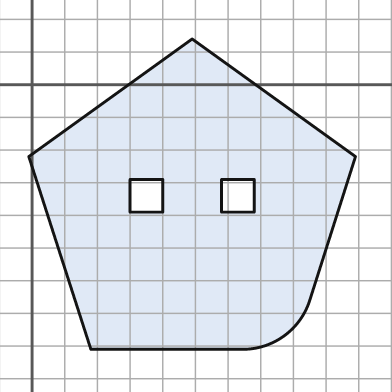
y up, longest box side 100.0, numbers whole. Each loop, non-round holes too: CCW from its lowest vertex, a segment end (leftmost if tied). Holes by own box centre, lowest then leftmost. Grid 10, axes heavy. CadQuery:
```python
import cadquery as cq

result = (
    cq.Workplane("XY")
    .moveTo(18.0, -81.0)
    .lineTo(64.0, -81.0)
    .threePointArc((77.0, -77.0), (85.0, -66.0))
    .lineTo(99.0, -22.0)
    .lineTo(49.0, 14.0)
    .lineTo(-1.0, -22.0)
    .close()
    .moveTo(30.0, -39.0)
    .lineTo(40.0, -39.0)
    .lineTo(40.0, -29.0)
    .lineTo(30.0, -29.0)
    .close()
    .moveTo(58.0, -39.0)
    .lineTo(68.0, -39.0)
    .lineTo(68.0, -29.0)
    .lineTo(58.0, -29.0)
    .close()
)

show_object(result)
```